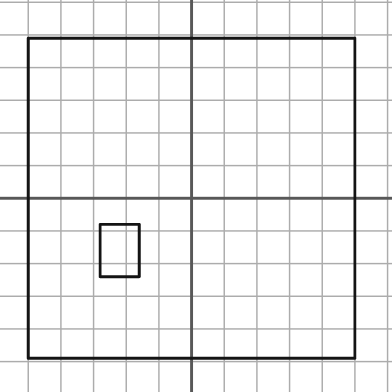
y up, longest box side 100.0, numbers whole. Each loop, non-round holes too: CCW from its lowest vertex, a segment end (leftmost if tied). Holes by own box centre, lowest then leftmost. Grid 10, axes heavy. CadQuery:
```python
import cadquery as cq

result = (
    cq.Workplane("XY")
    .moveTo(-50.0, -49.0)
    .lineTo(50.0, -49.0)
    .lineTo(50.0, 49.0)
    .lineTo(-50.0, 49.0)
    .close()
    .moveTo(-28.0, -24.0)
    .lineTo(-16.0, -24.0)
    .lineTo(-16.0, -8.0)
    .lineTo(-28.0, -8.0)
    .close()
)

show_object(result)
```